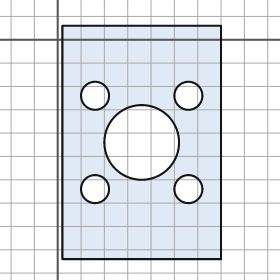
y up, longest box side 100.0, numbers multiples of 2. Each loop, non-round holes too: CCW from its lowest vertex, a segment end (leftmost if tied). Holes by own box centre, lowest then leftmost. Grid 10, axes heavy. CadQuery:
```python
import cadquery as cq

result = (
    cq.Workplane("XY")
    .moveTo(2.0, -94.0)
    .lineTo(70.0, -94.0)
    .lineTo(70.0, 6.0)
    .lineTo(2.0, 6.0)
    .close()
    .moveTo(16.0, -64.0)
    .circle(6.0)
    .moveTo(56.0, -64.0)
    .circle(6.0)
    .moveTo(36.0, -44.0)
    .circle(16.0)
    .moveTo(16.0, -24.0)
    .circle(6.0)
    .moveTo(56.0, -24.0)
    .circle(6.0)
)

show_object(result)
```